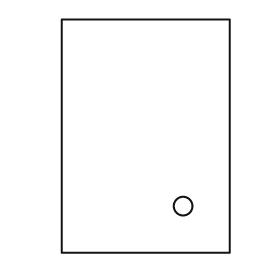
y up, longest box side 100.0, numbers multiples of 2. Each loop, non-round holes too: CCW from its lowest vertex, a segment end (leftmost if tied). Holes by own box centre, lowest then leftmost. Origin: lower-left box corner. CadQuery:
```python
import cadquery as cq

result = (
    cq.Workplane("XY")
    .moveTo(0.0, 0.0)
    .lineTo(72.0, 0.0)
    .lineTo(72.0, 100.0)
    .lineTo(0.0, 100.0)
    .close()
    .moveTo(52.0, 20.0)
    .circle(4.0)
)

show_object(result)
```